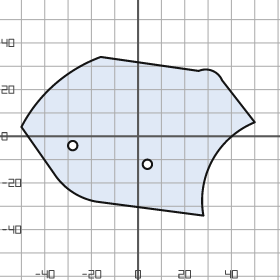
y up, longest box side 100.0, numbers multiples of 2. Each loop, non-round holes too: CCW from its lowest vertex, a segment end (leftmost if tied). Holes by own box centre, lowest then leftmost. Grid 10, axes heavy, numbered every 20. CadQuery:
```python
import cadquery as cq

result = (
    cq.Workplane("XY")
    .moveTo(28.0, -34.0)
    .threePointArc((32.0, -10.0), (50.0, 6.0))
    .lineTo(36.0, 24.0)
    .threePointArc((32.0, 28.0), (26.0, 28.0))
    .lineTo(-16.0, 34.0)
    .threePointArc((-36.0, 22.0), (-50.0, 4.0))
    .lineTo(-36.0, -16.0)
    .threePointArc((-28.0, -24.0), (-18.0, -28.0))
    .close()
    .moveTo(4.0, -12.0)
    .circle(2.0)
    .moveTo(-28.0, -4.0)
    .circle(2.0)
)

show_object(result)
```